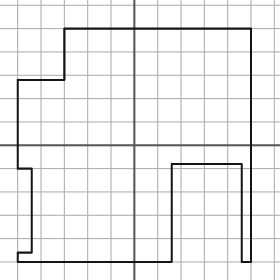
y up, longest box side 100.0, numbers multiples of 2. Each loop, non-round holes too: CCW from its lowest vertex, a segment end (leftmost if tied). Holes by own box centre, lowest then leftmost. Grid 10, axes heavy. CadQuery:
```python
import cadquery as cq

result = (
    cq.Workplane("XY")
    .moveTo(-50.0, -50.0)
    .lineTo(16.0, -50.0)
    .lineTo(16.0, -8.0)
    .lineTo(46.0, -8.0)
    .lineTo(46.0, -50.0)
    .lineTo(50.0, -50.0)
    .lineTo(50.0, 50.0)
    .lineTo(-30.0, 50.0)
    .lineTo(-30.0, 28.0)
    .lineTo(-50.0, 28.0)
    .lineTo(-50.0, -10.0)
    .lineTo(-44.0, -10.0)
    .lineTo(-44.0, -46.0)
    .lineTo(-50.0, -46.0)
    .close()
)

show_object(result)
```